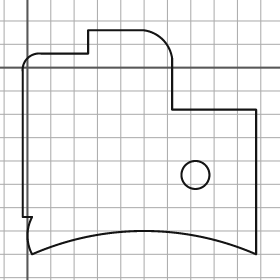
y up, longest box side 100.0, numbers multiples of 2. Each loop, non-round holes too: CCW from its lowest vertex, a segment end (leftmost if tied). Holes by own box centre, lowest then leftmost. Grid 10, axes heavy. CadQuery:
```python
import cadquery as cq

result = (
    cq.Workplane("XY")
    .moveTo(2.0, -80.0)
    .threePointArc((50.0, -70.0), (98.0, -80.0))
    .lineTo(98.0, -18.0)
    .lineTo(62.0, -18.0)
    .lineTo(62.0, 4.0)
    .threePointArc((58.0, 12.0), (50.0, 16.0))
    .lineTo(26.0, 16.0)
    .lineTo(26.0, 6.0)
    .lineTo(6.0, 6.0)
    .threePointArc((0.0, 4.0), (-2.0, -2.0))
    .lineTo(-2.0, -64.0)
    .lineTo(2.0, -64.0)
    .threePointArc((0.0, -72.0), (2.0, -80.0))
    .close()
    .moveTo(72.0, -46.0)
    .circle(6.0)
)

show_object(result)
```